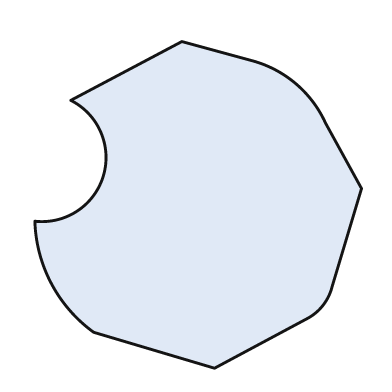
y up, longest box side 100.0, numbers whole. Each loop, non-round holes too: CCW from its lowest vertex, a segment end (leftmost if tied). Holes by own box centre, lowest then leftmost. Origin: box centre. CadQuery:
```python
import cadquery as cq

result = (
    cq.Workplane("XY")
    .moveTo(5.0, -50.0)
    .lineTo(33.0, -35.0)
    .threePointArc((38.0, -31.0), (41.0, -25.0))
    .lineTo(50.0, 5.0)
    .lineTo(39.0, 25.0)
    .threePointArc((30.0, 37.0), (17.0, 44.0))
    .lineTo(-5.0, 50.0)
    .lineTo(-39.0, 32.0)
    .threePointArc((-29.0, 9.0), (-50.0, -5.0))
    .threePointArc((-45.0, -24.0), (-32.0, -39.0))
    .close()
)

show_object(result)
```